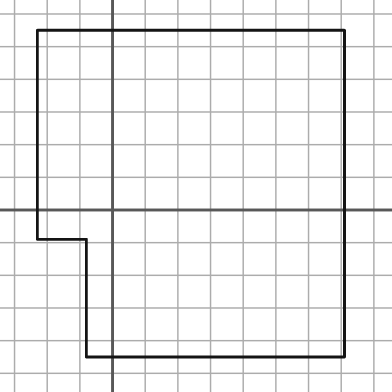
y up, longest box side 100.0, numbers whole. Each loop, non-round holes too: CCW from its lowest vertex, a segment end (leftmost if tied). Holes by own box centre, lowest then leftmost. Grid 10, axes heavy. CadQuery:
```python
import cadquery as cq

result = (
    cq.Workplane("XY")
    .moveTo(-8.0, -45.0)
    .lineTo(71.0, -45.0)
    .lineTo(71.0, 55.0)
    .lineTo(-23.0, 55.0)
    .lineTo(-23.0, -9.0)
    .lineTo(-8.0, -9.0)
    .close()
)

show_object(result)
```